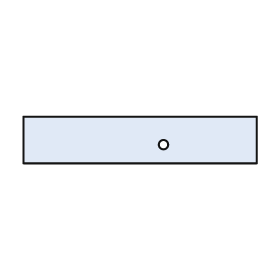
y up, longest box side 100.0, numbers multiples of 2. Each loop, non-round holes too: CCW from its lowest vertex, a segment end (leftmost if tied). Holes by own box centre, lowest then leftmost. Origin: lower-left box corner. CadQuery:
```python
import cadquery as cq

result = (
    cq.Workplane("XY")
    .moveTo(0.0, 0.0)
    .lineTo(100.0, 0.0)
    .lineTo(100.0, 20.0)
    .lineTo(0.0, 20.0)
    .close()
    .moveTo(60.0, 8.0)
    .circle(2.0)
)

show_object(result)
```